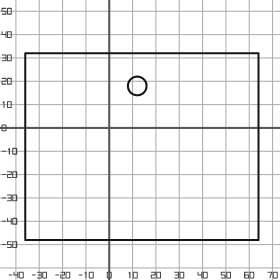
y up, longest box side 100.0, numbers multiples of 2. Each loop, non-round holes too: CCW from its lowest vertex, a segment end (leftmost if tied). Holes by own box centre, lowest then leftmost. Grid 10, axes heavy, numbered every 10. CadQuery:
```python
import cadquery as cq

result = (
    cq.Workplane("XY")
    .moveTo(-36.0, -48.0)
    .lineTo(64.0, -48.0)
    .lineTo(64.0, 32.0)
    .lineTo(-36.0, 32.0)
    .close()
    .moveTo(12.0, 18.0)
    .circle(4.0)
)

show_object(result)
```